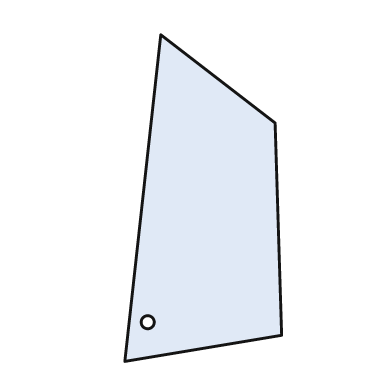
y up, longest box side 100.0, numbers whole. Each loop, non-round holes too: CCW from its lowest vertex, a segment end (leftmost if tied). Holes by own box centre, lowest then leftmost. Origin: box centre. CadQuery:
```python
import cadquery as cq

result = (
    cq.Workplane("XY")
    .moveTo(-24.0, -50.0)
    .lineTo(24.0, -42.0)
    .lineTo(22.0, 23.0)
    .lineTo(-13.0, 50.0)
    .close()
    .moveTo(-17.0, -38.0)
    .circle(2.0)
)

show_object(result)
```